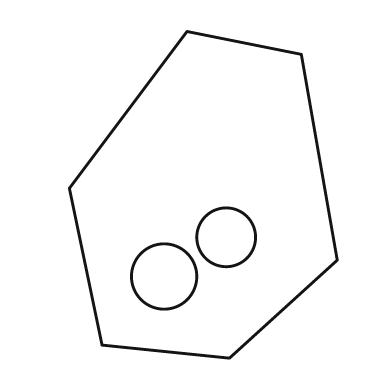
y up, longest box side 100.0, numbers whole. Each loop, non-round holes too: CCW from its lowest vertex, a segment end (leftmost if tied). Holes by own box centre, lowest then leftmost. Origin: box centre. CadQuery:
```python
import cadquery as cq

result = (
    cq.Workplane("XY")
    .moveTo(8.0, -50.0)
    .lineTo(41.0, -20.0)
    .lineTo(30.0, 43.0)
    .lineTo(-5.0, 50.0)
    .lineTo(-41.0, 2.0)
    .lineTo(-31.0, -46.0)
    .close()
    .moveTo(-12.0, -25.0)
    .circle(10.0)
    .moveTo(7.0, -13.0)
    .circle(9.0)
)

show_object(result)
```